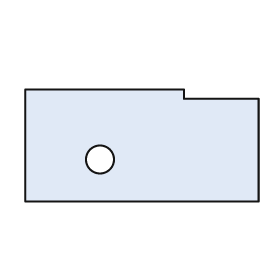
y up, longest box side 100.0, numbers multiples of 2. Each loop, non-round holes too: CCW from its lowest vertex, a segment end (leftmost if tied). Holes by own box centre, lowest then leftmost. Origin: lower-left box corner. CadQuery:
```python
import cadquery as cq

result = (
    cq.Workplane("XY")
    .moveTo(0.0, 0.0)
    .lineTo(100.0, 0.0)
    .lineTo(100.0, 44.0)
    .lineTo(68.0, 44.0)
    .lineTo(68.0, 48.0)
    .lineTo(0.0, 48.0)
    .close()
    .moveTo(32.0, 18.0)
    .circle(6.0)
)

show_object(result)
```